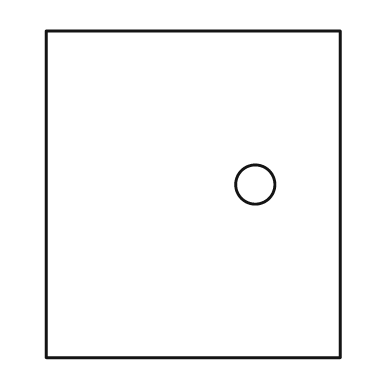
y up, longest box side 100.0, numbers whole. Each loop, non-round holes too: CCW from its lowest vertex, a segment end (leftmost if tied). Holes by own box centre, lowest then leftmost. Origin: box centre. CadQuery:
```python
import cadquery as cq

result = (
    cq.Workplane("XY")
    .moveTo(-45.0, -50.0)
    .lineTo(45.0, -50.0)
    .lineTo(45.0, 50.0)
    .lineTo(-45.0, 50.0)
    .close()
    .moveTo(19.0, 3.0)
    .circle(6.0)
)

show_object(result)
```